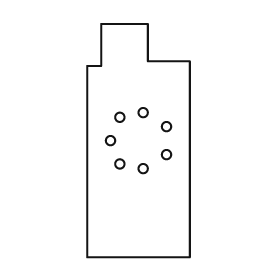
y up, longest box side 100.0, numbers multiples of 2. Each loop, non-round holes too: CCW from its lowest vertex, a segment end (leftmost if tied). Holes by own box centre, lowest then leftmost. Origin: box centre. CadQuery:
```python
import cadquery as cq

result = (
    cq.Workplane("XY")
    .moveTo(-22.0, -50.0)
    .lineTo(22.0, -50.0)
    .lineTo(22.0, 34.0)
    .lineTo(4.0, 34.0)
    .lineTo(4.0, 50.0)
    .lineTo(-16.0, 50.0)
    .lineTo(-16.0, 32.0)
    .lineTo(-22.0, 32.0)
    .close()
    .moveTo(2.0, -12.0)
    .circle(2.0)
    .moveTo(-8.0, -10.0)
    .circle(2.0)
    .moveTo(12.0, -6.0)
    .circle(2.0)
    .moveTo(-12.0, 0.0)
    .circle(2.0)
    .moveTo(12.0, 6.0)
    .circle(2.0)
    .moveTo(-8.0, 10.0)
    .circle(2.0)
    .moveTo(2.0, 12.0)
    .circle(2.0)
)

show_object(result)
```